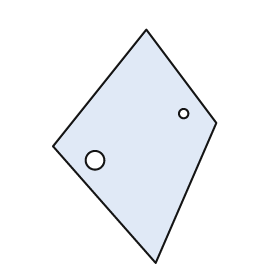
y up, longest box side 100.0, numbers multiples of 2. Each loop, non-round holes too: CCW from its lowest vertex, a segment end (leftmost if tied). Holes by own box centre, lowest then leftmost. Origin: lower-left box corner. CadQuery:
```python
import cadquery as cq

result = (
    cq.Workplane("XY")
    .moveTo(44.0, 0.0)
    .lineTo(70.0, 60.0)
    .lineTo(40.0, 100.0)
    .lineTo(0.0, 50.0)
    .close()
    .moveTo(18.0, 44.0)
    .circle(4.0)
    .moveTo(56.0, 64.0)
    .circle(2.0)
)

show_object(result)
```